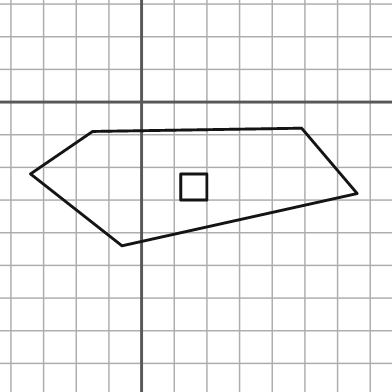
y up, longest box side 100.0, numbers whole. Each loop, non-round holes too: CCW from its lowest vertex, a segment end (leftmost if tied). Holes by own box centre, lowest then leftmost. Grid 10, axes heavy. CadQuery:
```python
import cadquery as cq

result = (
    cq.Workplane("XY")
    .moveTo(-6.0, -44.0)
    .lineTo(66.0, -28.0)
    .lineTo(49.0, -8.0)
    .lineTo(-15.0, -9.0)
    .lineTo(-34.0, -22.0)
    .close()
    .moveTo(12.0, -30.0)
    .lineTo(20.0, -30.0)
    .lineTo(20.0, -22.0)
    .lineTo(12.0, -22.0)
    .close()
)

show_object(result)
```